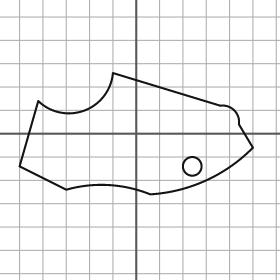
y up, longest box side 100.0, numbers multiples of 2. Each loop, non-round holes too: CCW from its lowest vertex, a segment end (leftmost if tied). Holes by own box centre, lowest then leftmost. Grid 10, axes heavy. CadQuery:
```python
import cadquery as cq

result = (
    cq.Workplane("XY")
    .moveTo(6.0, -26.0)
    .threePointArc((30.0, -20.0), (50.0, -6.0))
    .lineTo(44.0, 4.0)
    .threePointArc((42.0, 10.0), (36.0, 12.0))
    .lineTo(-10.0, 26.0)
    .threePointArc((-22.0, 10.0), (-42.0, 14.0))
    .lineTo(-50.0, -14.0)
    .lineTo(-30.0, -24.0)
    .threePointArc((-12.0, -22.0), (6.0, -26.0))
    .close()
    .moveTo(24.0, -14.0)
    .circle(4.0)
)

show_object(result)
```